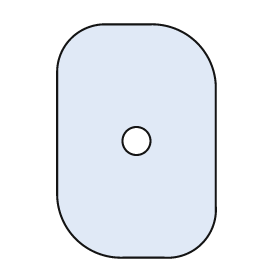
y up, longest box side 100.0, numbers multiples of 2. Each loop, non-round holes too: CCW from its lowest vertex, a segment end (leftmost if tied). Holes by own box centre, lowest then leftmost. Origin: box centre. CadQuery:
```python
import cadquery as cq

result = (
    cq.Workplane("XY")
    .moveTo(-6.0, -50.0)
    .lineTo(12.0, -50.0)
    .threePointArc((28.0, -44.0), (34.0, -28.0))
    .lineTo(34.0, 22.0)
    .threePointArc((26.0, 42.0), (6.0, 50.0))
    .lineTo(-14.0, 50.0)
    .threePointArc((-28.0, 44.0), (-34.0, 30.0))
    .lineTo(-34.0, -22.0)
    .threePointArc((-26.0, -42.0), (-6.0, -50.0))
    .close()
    .moveTo(0.0, 0.0)
    .circle(6.0)
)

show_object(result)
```